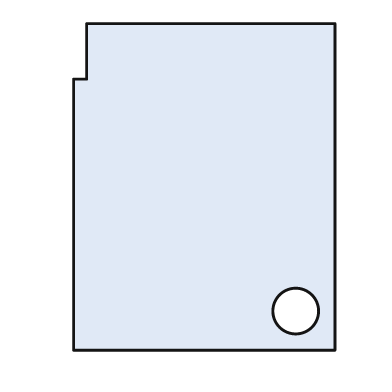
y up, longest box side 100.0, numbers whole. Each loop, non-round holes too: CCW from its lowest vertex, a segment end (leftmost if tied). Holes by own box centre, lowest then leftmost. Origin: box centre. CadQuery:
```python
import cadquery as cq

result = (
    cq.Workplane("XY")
    .moveTo(-40.0, -50.0)
    .lineTo(40.0, -50.0)
    .lineTo(40.0, 50.0)
    .lineTo(-36.0, 50.0)
    .lineTo(-36.0, 33.0)
    .lineTo(-40.0, 33.0)
    .close()
    .moveTo(28.0, -38.0)
    .circle(7.0)
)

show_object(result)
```